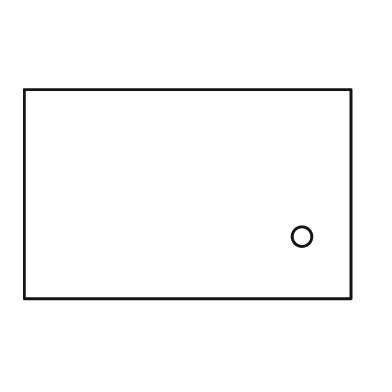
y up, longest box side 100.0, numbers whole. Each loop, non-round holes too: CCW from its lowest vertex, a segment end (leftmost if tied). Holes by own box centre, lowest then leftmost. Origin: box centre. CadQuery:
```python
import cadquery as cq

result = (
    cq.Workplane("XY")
    .moveTo(-50.0, -32.0)
    .lineTo(50.0, -32.0)
    .lineTo(50.0, 32.0)
    .lineTo(-50.0, 32.0)
    .close()
    .moveTo(35.0, -13.0)
    .circle(3.0)
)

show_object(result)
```